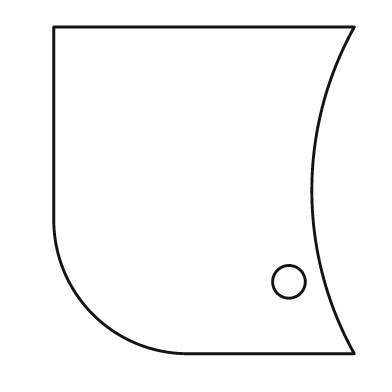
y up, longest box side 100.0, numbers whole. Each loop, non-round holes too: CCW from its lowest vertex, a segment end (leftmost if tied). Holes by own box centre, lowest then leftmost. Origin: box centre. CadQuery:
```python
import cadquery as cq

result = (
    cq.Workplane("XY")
    .moveTo(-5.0, -50.0)
    .lineTo(46.0, -50.0)
    .threePointArc((33.0, 0.0), (46.0, 50.0))
    .lineTo(-46.0, 50.0)
    .lineTo(-46.0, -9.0)
    .threePointArc((-34.0, -38.0), (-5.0, -50.0))
    .close()
    .moveTo(26.0, -28.0)
    .circle(5.0)
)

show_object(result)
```